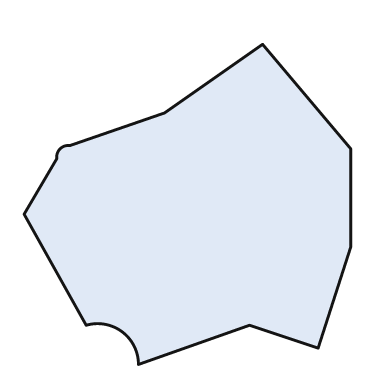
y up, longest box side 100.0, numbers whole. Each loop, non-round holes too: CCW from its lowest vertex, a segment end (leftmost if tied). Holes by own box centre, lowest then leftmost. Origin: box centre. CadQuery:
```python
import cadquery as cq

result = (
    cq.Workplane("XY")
    .moveTo(-15.0, -49.0)
    .lineTo(19.0, -37.0)
    .lineTo(40.0, -44.0)
    .lineTo(50.0, -13.0)
    .lineTo(50.0, 17.0)
    .lineTo(23.0, 49.0)
    .lineTo(-7.0, 28.0)
    .lineTo(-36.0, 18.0)
    .threePointArc((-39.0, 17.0), (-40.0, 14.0))
    .lineTo(-50.0, -3.0)
    .lineTo(-31.0, -37.0)
    .threePointArc((-20.0, -39.0), (-15.0, -49.0))
    .close()
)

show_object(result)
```